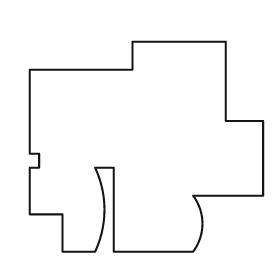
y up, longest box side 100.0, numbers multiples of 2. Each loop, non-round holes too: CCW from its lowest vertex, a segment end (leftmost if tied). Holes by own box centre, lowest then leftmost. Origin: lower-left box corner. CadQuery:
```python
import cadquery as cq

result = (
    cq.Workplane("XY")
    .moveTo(14.0, 0.0)
    .lineTo(28.0, 0.0)
    .threePointArc((32.0, 18.0), (28.0, 36.0))
    .lineTo(36.0, 36.0)
    .lineTo(36.0, 0.0)
    .lineTo(70.0, 0.0)
    .threePointArc((74.0, 12.0), (70.0, 24.0))
    .lineTo(100.0, 24.0)
    .lineTo(100.0, 56.0)
    .lineTo(84.0, 56.0)
    .lineTo(84.0, 90.0)
    .lineTo(44.0, 90.0)
    .lineTo(44.0, 78.0)
    .lineTo(0.0, 78.0)
    .lineTo(0.0, 42.0)
    .lineTo(4.0, 42.0)
    .lineTo(4.0, 36.0)
    .lineTo(0.0, 36.0)
    .lineTo(0.0, 16.0)
    .lineTo(14.0, 16.0)
    .close()
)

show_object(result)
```